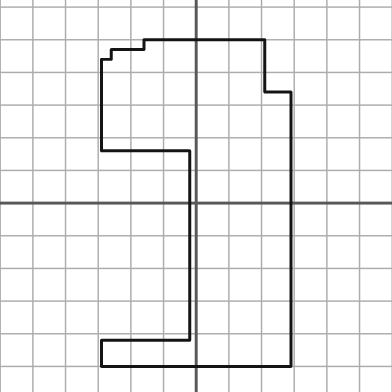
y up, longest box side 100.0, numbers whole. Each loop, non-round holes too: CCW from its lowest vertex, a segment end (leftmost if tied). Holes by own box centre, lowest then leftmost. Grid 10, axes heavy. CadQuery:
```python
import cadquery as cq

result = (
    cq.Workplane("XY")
    .moveTo(-29.0, -50.0)
    .lineTo(29.0, -50.0)
    .lineTo(29.0, 34.0)
    .lineTo(21.0, 34.0)
    .lineTo(21.0, 50.0)
    .lineTo(-16.0, 50.0)
    .lineTo(-16.0, 47.0)
    .lineTo(-26.0, 47.0)
    .lineTo(-26.0, 44.0)
    .lineTo(-29.0, 44.0)
    .lineTo(-29.0, 16.0)
    .lineTo(-2.0, 16.0)
    .lineTo(-2.0, -42.0)
    .lineTo(-29.0, -42.0)
    .close()
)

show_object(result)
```